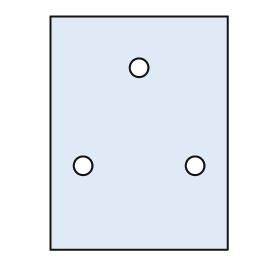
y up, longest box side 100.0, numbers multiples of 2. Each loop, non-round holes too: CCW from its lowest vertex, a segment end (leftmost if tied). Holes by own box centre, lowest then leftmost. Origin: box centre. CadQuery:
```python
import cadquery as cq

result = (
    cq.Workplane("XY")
    .moveTo(-38.0, -50.0)
    .lineTo(38.0, -50.0)
    .lineTo(38.0, 50.0)
    .lineTo(-38.0, 50.0)
    .close()
    .moveTo(-24.0, -14.0)
    .circle(4.0)
    .moveTo(24.0, -14.0)
    .circle(4.0)
    .moveTo(0.0, 28.0)
    .circle(4.0)
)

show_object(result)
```